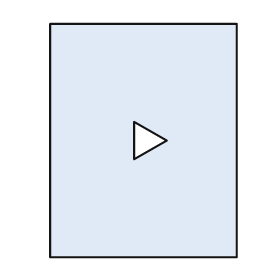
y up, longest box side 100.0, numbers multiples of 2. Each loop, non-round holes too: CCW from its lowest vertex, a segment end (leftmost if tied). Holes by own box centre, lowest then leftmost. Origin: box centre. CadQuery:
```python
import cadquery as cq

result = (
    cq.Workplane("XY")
    .moveTo(-40.0, -50.0)
    .lineTo(40.0, -50.0)
    .lineTo(40.0, 50.0)
    .lineTo(-40.0, 50.0)
    .close()
    .moveTo(-4.0, -8.0)
    .lineTo(10.0, 0.0)
    .lineTo(-4.0, 8.0)
    .close()
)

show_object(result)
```